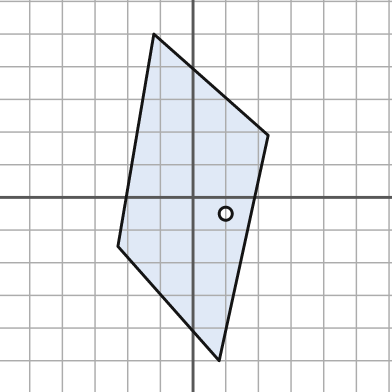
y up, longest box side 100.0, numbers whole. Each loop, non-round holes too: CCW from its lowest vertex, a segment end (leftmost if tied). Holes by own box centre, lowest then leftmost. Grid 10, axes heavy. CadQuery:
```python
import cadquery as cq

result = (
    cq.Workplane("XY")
    .moveTo(8.0, -50.0)
    .lineTo(23.0, 19.0)
    .lineTo(-12.0, 50.0)
    .lineTo(-23.0, -15.0)
    .close()
    .moveTo(10.0, -5.0)
    .circle(2.0)
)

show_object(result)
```